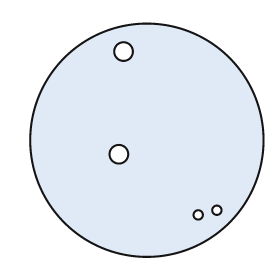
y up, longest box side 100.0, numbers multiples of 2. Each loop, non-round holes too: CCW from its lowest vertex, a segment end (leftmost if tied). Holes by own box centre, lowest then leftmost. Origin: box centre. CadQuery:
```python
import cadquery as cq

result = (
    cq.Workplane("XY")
    .moveTo(0.0, 0.0)
    .circle(50.0)
    .moveTo(22.0, -32.0)
    .circle(2.0)
    .moveTo(30.0, -30.0)
    .circle(2.0)
    .moveTo(-12.0, -6.0)
    .circle(4.0)
    .moveTo(-10.0, 38.0)
    .circle(4.0)
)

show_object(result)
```